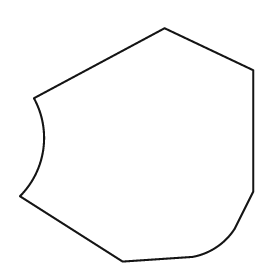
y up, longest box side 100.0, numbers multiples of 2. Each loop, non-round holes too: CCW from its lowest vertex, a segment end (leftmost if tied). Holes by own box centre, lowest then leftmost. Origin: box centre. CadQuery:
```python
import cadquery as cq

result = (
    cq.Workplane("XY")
    .moveTo(-6.0, -50.0)
    .lineTo(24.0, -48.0)
    .threePointArc((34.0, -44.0), (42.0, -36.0))
    .lineTo(50.0, -20.0)
    .lineTo(50.0, 32.0)
    .lineTo(12.0, 50.0)
    .lineTo(-44.0, 20.0)
    .threePointArc((-40.0, -2.0), (-50.0, -22.0))
    .close()
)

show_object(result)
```